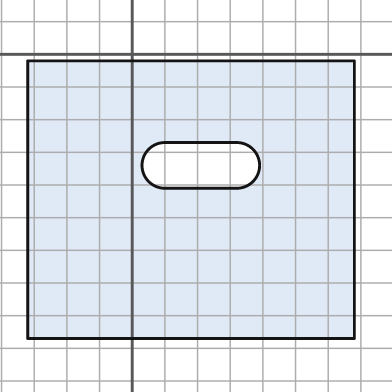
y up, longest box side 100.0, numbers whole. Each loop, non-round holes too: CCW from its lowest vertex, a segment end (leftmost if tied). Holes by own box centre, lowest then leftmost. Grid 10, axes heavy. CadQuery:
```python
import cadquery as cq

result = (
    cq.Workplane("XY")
    .moveTo(-32.0, -87.0)
    .lineTo(68.0, -87.0)
    .lineTo(68.0, -2.0)
    .lineTo(-32.0, -2.0)
    .close()
    .moveTo(10.0, -41.0)
    .lineTo(32.0, -41.0)
    .threePointArc((39.0, -34.0), (32.0, -27.0))
    .lineTo(10.0, -27.0)
    .threePointArc((3.0, -34.0), (10.0, -41.0))
    .close()
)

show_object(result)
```